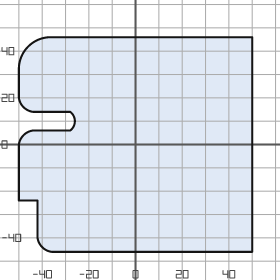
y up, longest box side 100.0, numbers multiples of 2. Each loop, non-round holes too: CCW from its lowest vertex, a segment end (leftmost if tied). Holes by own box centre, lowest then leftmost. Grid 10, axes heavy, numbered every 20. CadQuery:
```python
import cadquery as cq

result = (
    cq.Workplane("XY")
    .moveTo(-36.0, -46.0)
    .lineTo(50.0, -46.0)
    .lineTo(50.0, 46.0)
    .lineTo(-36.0, 46.0)
    .threePointArc((-46.0, 42.0), (-50.0, 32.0))
    .lineTo(-50.0, 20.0)
    .threePointArc((-48.0, 16.0), (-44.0, 14.0))
    .lineTo(-28.0, 14.0)
    .threePointArc((-26.0, 10.0), (-28.0, 6.0))
    .lineTo(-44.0, 6.0)
    .threePointArc((-48.0, 4.0), (-50.0, 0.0))
    .lineTo(-50.0, -24.0)
    .lineTo(-42.0, -24.0)
    .lineTo(-42.0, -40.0)
    .threePointArc((-40.0, -44.0), (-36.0, -46.0))
    .close()
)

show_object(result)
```